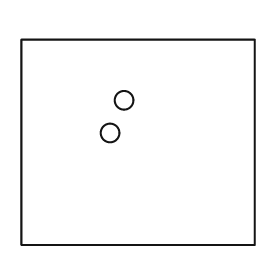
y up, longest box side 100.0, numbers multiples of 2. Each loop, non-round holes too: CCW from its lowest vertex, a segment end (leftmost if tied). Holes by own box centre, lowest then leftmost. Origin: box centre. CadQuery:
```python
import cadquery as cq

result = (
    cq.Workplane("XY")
    .moveTo(-50.0, -44.0)
    .lineTo(50.0, -44.0)
    .lineTo(50.0, 44.0)
    .lineTo(-50.0, 44.0)
    .close()
    .moveTo(-12.0, 4.0)
    .circle(4.0)
    .moveTo(-6.0, 18.0)
    .circle(4.0)
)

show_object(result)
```